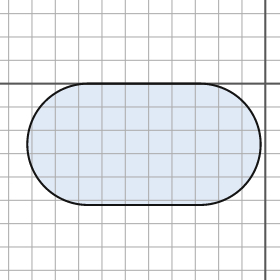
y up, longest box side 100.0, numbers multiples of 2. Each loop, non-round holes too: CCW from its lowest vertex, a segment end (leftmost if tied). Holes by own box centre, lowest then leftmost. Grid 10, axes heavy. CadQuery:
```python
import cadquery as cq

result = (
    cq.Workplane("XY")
    .moveTo(-76.0, -52.0)
    .lineTo(-28.0, -52.0)
    .threePointArc((-2.0, -26.0), (-28.0, 0.0))
    .lineTo(-76.0, 0.0)
    .threePointArc((-102.0, -26.0), (-76.0, -52.0))
    .close()
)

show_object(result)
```